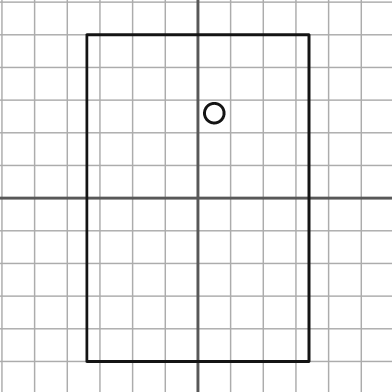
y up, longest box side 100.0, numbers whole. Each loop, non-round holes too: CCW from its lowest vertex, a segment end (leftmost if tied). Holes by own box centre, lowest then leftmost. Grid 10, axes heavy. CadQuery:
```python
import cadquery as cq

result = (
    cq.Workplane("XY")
    .moveTo(-34.0, -50.0)
    .lineTo(34.0, -50.0)
    .lineTo(34.0, 50.0)
    .lineTo(-34.0, 50.0)
    .close()
    .moveTo(5.0, 26.0)
    .circle(3.0)
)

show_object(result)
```